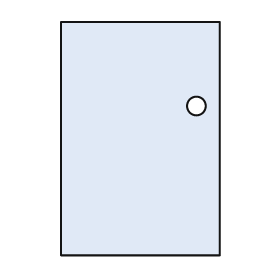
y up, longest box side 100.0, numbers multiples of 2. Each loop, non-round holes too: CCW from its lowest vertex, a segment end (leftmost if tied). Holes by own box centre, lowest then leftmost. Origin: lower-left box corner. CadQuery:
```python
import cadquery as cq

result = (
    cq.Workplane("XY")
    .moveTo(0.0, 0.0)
    .lineTo(68.0, 0.0)
    .lineTo(68.0, 100.0)
    .lineTo(0.0, 100.0)
    .close()
    .moveTo(58.0, 64.0)
    .circle(4.0)
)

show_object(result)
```